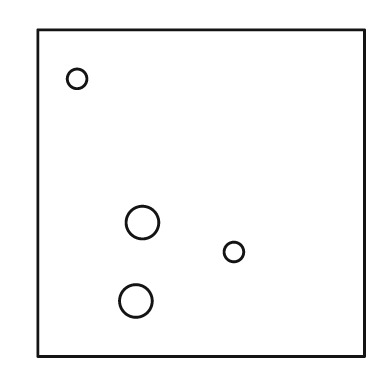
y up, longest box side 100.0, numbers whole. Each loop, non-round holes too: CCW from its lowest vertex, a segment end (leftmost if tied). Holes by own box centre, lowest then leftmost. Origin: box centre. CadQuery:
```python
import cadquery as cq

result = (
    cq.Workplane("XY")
    .moveTo(-50.0, -50.0)
    .lineTo(50.0, -50.0)
    .lineTo(50.0, 50.0)
    .lineTo(-50.0, 50.0)
    .close()
    .moveTo(-20.0, -33.0)
    .circle(5.0)
    .moveTo(10.0, -18.0)
    .circle(3.0)
    .moveTo(-18.0, -9.0)
    .circle(5.0)
    .moveTo(-38.0, 35.0)
    .circle(3.0)
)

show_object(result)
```